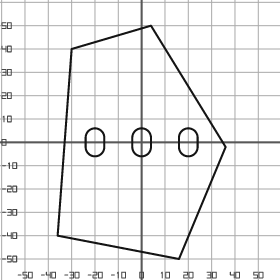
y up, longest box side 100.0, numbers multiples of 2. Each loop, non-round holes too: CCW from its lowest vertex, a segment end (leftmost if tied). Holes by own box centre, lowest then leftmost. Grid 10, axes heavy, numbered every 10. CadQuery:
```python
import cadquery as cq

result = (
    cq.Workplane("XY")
    .moveTo(16.0, -50.0)
    .lineTo(36.0, -2.0)
    .lineTo(4.0, 50.0)
    .lineTo(-30.0, 40.0)
    .lineTo(-36.0, -40.0)
    .close()
    .moveTo(-24.0, -2.0)
    .threePointArc((-20.0, -6.0), (-16.0, -2.0))
    .lineTo(-16.0, 2.0)
    .threePointArc((-20.0, 6.0), (-24.0, 2.0))
    .close()
    .moveTo(-4.0, -2.0)
    .threePointArc((0.0, -6.0), (4.0, -2.0))
    .lineTo(4.0, 2.0)
    .threePointArc((0.0, 6.0), (-4.0, 2.0))
    .close()
    .moveTo(16.0, -2.0)
    .threePointArc((20.0, -6.0), (24.0, -2.0))
    .lineTo(24.0, 2.0)
    .threePointArc((20.0, 6.0), (16.0, 2.0))
    .close()
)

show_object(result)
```